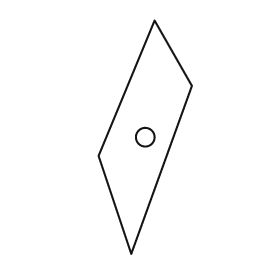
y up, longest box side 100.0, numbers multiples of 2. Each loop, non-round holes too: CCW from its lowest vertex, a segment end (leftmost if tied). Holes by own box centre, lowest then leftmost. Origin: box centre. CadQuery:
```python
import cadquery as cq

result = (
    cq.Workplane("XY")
    .moveTo(-6.0, -50.0)
    .lineTo(20.0, 22.0)
    .lineTo(4.0, 50.0)
    .lineTo(-20.0, -8.0)
    .close()
    .moveTo(0.0, 0.0)
    .circle(4.0)
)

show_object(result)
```